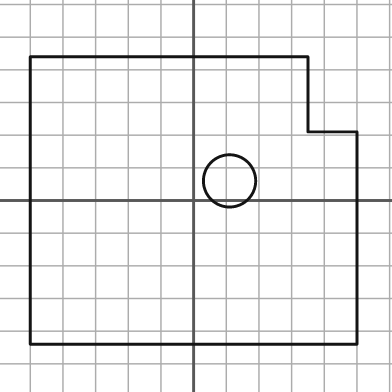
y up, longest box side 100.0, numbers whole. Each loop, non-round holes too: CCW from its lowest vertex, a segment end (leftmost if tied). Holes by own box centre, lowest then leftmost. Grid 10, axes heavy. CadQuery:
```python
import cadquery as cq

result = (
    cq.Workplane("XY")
    .moveTo(-50.0, -44.0)
    .lineTo(50.0, -44.0)
    .lineTo(50.0, 21.0)
    .lineTo(35.0, 21.0)
    .lineTo(35.0, 44.0)
    .lineTo(-50.0, 44.0)
    .close()
    .moveTo(11.0, 6.0)
    .circle(8.0)
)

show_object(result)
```